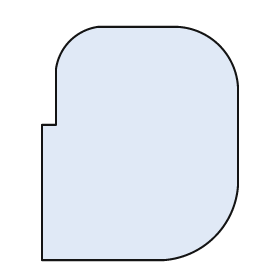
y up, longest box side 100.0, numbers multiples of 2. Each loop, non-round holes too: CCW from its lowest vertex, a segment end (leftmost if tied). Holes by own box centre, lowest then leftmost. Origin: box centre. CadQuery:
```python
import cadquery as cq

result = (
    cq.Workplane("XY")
    .moveTo(-42.0, -50.0)
    .lineTo(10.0, -50.0)
    .threePointArc((32.0, -40.0), (42.0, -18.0))
    .lineTo(42.0, 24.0)
    .threePointArc((34.0, 42.0), (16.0, 50.0))
    .lineTo(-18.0, 50.0)
    .threePointArc((-30.0, 44.0), (-36.0, 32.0))
    .lineTo(-36.0, 8.0)
    .lineTo(-42.0, 8.0)
    .close()
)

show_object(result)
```